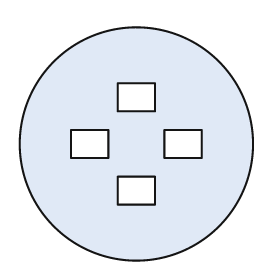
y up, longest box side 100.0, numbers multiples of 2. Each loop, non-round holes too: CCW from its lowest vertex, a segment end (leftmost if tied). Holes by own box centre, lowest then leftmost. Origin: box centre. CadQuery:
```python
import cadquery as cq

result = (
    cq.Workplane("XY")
    .moveTo(0.0, 0.0)
    .circle(50.0)
    .moveTo(-8.0, -26.0)
    .lineTo(8.0, -26.0)
    .lineTo(8.0, -14.0)
    .lineTo(-8.0, -14.0)
    .close()
    .moveTo(-28.0, -6.0)
    .lineTo(-12.0, -6.0)
    .lineTo(-12.0, 6.0)
    .lineTo(-28.0, 6.0)
    .close()
    .moveTo(12.0, -6.0)
    .lineTo(28.0, -6.0)
    .lineTo(28.0, 6.0)
    .lineTo(12.0, 6.0)
    .close()
    .moveTo(-8.0, 14.0)
    .lineTo(8.0, 14.0)
    .lineTo(8.0, 26.0)
    .lineTo(-8.0, 26.0)
    .close()
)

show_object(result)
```